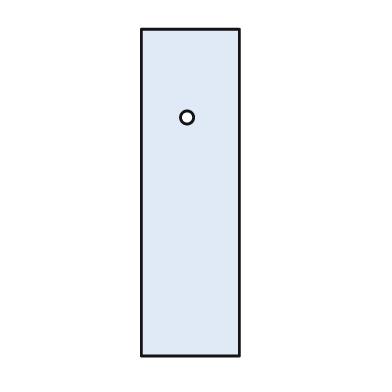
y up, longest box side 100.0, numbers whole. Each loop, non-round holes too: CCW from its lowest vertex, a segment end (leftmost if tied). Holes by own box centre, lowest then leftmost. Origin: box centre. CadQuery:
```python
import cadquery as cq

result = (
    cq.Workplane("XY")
    .moveTo(-15.0, -50.0)
    .lineTo(15.0, -50.0)
    .lineTo(15.0, 50.0)
    .lineTo(-15.0, 50.0)
    .close()
    .moveTo(-1.0, 23.0)
    .circle(2.0)
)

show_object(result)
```